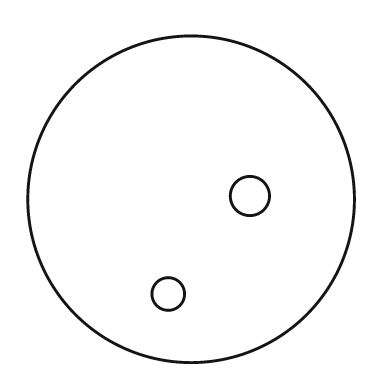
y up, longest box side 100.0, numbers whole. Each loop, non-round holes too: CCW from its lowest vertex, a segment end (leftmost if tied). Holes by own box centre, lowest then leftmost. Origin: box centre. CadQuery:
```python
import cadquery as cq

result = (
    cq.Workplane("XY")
    .moveTo(0.0, 0.0)
    .circle(50.0)
    .moveTo(-7.0, -29.0)
    .circle(5.0)
    .moveTo(18.0, 1.0)
    .circle(6.0)
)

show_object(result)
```